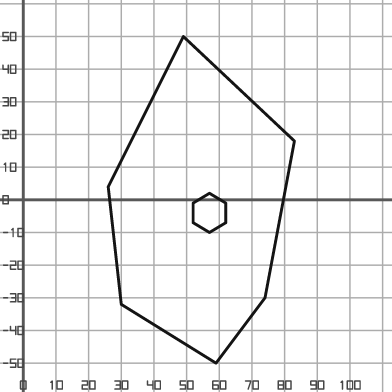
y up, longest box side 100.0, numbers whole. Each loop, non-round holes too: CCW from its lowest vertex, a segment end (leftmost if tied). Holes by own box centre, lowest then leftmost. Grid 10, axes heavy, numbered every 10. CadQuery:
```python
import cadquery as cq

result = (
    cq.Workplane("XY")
    .moveTo(59.0, -50.0)
    .lineTo(74.0, -30.0)
    .lineTo(83.0, 18.0)
    .lineTo(49.0, 50.0)
    .lineTo(26.0, 4.0)
    .lineTo(30.0, -32.0)
    .close()
    .moveTo(57.0, -10.0)
    .lineTo(62.0, -7.0)
    .lineTo(62.0, -1.0)
    .lineTo(57.0, 2.0)
    .lineTo(52.0, -1.0)
    .lineTo(52.0, -7.0)
    .close()
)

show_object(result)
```